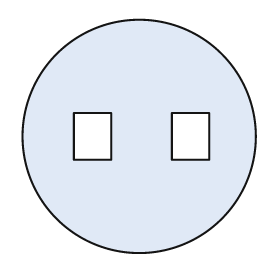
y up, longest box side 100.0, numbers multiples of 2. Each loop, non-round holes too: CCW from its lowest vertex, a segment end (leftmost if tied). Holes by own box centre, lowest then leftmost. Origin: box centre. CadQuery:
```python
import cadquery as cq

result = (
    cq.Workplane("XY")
    .moveTo(0.0, 0.0)
    .circle(50.0)
    .moveTo(-28.0, -10.0)
    .lineTo(-12.0, -10.0)
    .lineTo(-12.0, 10.0)
    .lineTo(-28.0, 10.0)
    .close()
    .moveTo(14.0, -10.0)
    .lineTo(30.0, -10.0)
    .lineTo(30.0, 10.0)
    .lineTo(14.0, 10.0)
    .close()
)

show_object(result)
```